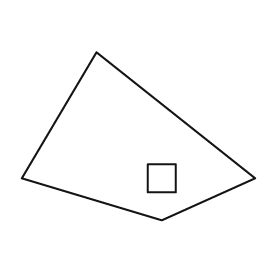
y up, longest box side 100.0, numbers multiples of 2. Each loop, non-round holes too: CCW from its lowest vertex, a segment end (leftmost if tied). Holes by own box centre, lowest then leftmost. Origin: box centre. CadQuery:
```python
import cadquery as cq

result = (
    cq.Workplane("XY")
    .moveTo(10.0, -36.0)
    .lineTo(50.0, -18.0)
    .lineTo(-18.0, 36.0)
    .lineTo(-50.0, -18.0)
    .close()
    .moveTo(4.0, -24.0)
    .lineTo(16.0, -24.0)
    .lineTo(16.0, -12.0)
    .lineTo(4.0, -12.0)
    .close()
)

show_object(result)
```